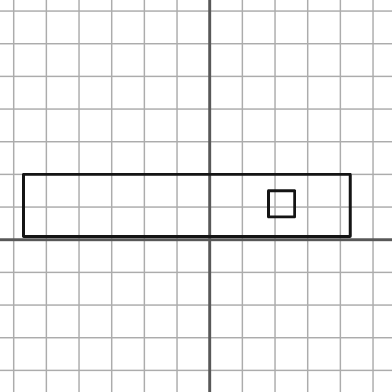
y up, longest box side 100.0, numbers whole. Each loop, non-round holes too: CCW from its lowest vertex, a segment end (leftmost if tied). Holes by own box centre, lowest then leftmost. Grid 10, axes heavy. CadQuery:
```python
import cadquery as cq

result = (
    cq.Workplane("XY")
    .moveTo(-57.0, 1.0)
    .lineTo(43.0, 1.0)
    .lineTo(43.0, 20.0)
    .lineTo(-57.0, 20.0)
    .close()
    .moveTo(18.0, 7.0)
    .lineTo(26.0, 7.0)
    .lineTo(26.0, 15.0)
    .lineTo(18.0, 15.0)
    .close()
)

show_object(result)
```